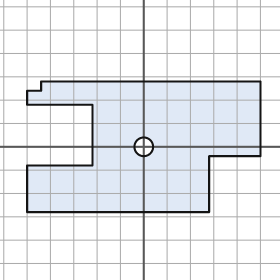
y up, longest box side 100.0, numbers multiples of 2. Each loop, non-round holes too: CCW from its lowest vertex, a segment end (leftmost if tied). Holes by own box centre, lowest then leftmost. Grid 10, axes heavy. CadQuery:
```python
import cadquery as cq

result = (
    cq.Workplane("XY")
    .moveTo(-50.0, -28.0)
    .lineTo(28.0, -28.0)
    .lineTo(28.0, -4.0)
    .lineTo(50.0, -4.0)
    .lineTo(50.0, 28.0)
    .lineTo(-44.0, 28.0)
    .lineTo(-44.0, 24.0)
    .lineTo(-50.0, 24.0)
    .lineTo(-50.0, 18.0)
    .lineTo(-22.0, 18.0)
    .lineTo(-22.0, -8.0)
    .lineTo(-50.0, -8.0)
    .close()
    .moveTo(0.0, 0.0)
    .circle(4.0)
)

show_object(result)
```